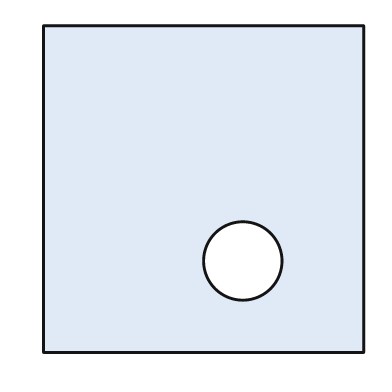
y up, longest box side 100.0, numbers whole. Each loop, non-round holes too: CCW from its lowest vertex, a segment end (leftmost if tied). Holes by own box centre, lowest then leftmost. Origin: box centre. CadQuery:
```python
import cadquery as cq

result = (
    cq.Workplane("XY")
    .moveTo(-49.0, -50.0)
    .lineTo(49.0, -50.0)
    .lineTo(49.0, 50.0)
    .lineTo(-49.0, 50.0)
    .close()
    .moveTo(12.0, -22.0)
    .circle(12.0)
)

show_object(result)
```